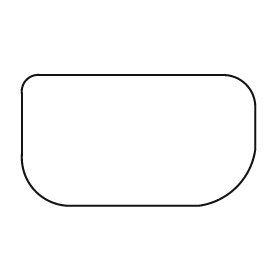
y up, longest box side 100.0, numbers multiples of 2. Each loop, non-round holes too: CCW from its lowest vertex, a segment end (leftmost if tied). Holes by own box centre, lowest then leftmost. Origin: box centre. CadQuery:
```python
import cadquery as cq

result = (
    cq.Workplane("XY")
    .moveTo(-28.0, -28.0)
    .lineTo(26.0, -28.0)
    .threePointArc((42.0, -20.0), (50.0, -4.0))
    .lineTo(50.0, 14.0)
    .threePointArc((46.0, 24.0), (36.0, 28.0))
    .lineTo(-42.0, 28.0)
    .threePointArc((-48.0, 26.0), (-50.0, 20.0))
    .lineTo(-50.0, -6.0)
    .threePointArc((-44.0, -22.0), (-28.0, -28.0))
    .close()
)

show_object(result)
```